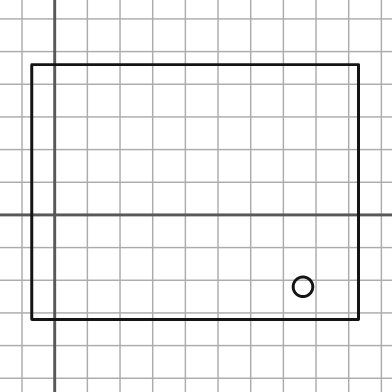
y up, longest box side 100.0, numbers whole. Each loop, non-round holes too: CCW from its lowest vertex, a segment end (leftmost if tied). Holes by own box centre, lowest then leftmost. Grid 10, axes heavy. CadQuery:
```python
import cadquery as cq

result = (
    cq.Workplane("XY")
    .moveTo(-7.0, -32.0)
    .lineTo(93.0, -32.0)
    .lineTo(93.0, 46.0)
    .lineTo(-7.0, 46.0)
    .close()
    .moveTo(76.0, -22.0)
    .circle(3.0)
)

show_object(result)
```